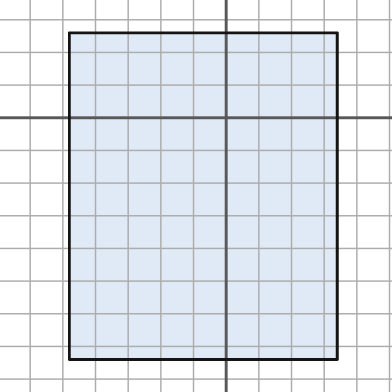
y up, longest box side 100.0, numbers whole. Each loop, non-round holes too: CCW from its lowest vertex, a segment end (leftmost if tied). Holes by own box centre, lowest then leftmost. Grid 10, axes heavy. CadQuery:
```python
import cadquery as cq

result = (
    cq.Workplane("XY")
    .moveTo(-48.0, -74.0)
    .lineTo(34.0, -74.0)
    .lineTo(34.0, 26.0)
    .lineTo(-48.0, 26.0)
    .close()
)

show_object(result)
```